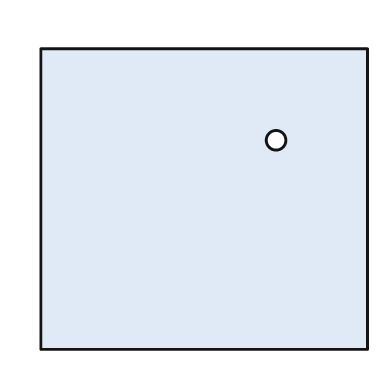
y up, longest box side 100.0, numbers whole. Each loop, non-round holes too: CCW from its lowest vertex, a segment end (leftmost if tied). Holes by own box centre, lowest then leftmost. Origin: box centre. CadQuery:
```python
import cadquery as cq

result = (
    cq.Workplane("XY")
    .moveTo(-50.0, -46.0)
    .lineTo(50.0, -46.0)
    .lineTo(50.0, 46.0)
    .lineTo(-50.0, 46.0)
    .close()
    .moveTo(22.0, 18.0)
    .circle(3.0)
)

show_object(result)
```